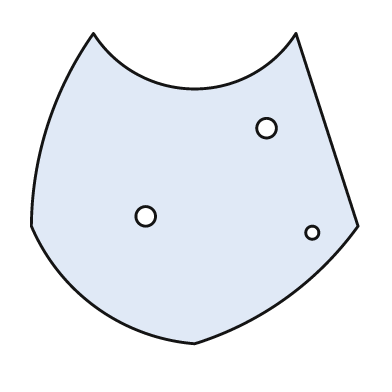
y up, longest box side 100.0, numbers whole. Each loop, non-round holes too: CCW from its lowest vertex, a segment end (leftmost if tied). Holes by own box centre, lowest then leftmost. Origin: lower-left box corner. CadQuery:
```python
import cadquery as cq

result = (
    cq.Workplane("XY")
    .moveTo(50.0, 0.0)
    .threePointArc((78.0, 14.0), (100.0, 36.0))
    .lineTo(81.0, 95.0)
    .threePointArc((50.0, 78.0), (19.0, 95.0))
    .threePointArc((5.0, 67.0), (0.0, 36.0))
    .threePointArc((20.0, 11.0), (50.0, 0.0))
    .close()
    .moveTo(86.0, 34.0)
    .circle(2.0)
    .moveTo(35.0, 39.0)
    .circle(3.0)
    .moveTo(72.0, 66.0)
    .circle(3.0)
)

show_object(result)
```